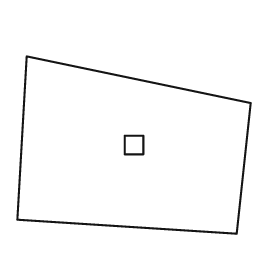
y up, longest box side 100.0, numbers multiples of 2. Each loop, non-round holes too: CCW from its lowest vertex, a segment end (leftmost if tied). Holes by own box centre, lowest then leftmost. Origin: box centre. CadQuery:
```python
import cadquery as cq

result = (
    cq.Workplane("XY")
    .moveTo(44.0, -38.0)
    .lineTo(50.0, 18.0)
    .lineTo(-46.0, 38.0)
    .lineTo(-50.0, -32.0)
    .close()
    .moveTo(-4.0, -4.0)
    .lineTo(4.0, -4.0)
    .lineTo(4.0, 4.0)
    .lineTo(-4.0, 4.0)
    .close()
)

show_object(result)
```